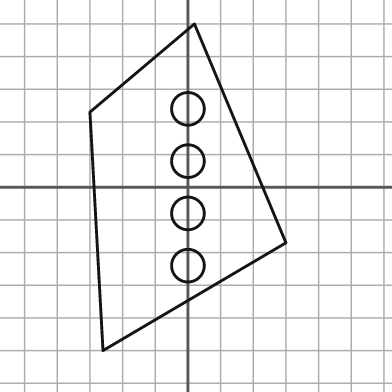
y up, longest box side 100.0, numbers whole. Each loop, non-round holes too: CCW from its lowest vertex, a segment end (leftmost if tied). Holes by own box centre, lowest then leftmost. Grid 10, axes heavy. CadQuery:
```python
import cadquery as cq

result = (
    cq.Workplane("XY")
    .moveTo(-26.0, -50.0)
    .lineTo(30.0, -17.0)
    .lineTo(2.0, 50.0)
    .lineTo(-30.0, 23.0)
    .close()
    .moveTo(0.0, -24.0)
    .circle(5.0)
    .moveTo(0.0, -8.0)
    .circle(5.0)
    .moveTo(0.0, 8.0)
    .circle(5.0)
    .moveTo(0.0, 24.0)
    .circle(5.0)
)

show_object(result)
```